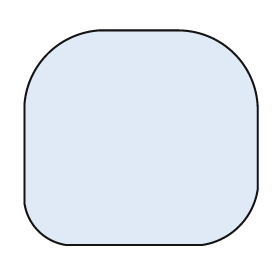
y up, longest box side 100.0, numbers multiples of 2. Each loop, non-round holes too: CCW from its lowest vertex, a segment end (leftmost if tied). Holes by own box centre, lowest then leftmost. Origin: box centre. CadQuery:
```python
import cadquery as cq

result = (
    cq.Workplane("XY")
    .moveTo(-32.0, -46.0)
    .lineTo(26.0, -46.0)
    .threePointArc((42.0, -38.0), (50.0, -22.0))
    .lineTo(50.0, 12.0)
    .threePointArc((40.0, 36.0), (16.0, 46.0))
    .lineTo(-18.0, 46.0)
    .threePointArc((-40.0, 36.0), (-50.0, 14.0))
    .lineTo(-50.0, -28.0)
    .threePointArc((-44.0, -40.0), (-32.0, -46.0))
    .close()
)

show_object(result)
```